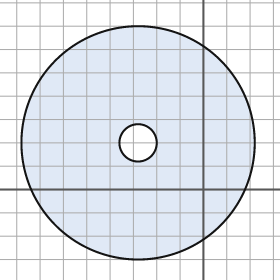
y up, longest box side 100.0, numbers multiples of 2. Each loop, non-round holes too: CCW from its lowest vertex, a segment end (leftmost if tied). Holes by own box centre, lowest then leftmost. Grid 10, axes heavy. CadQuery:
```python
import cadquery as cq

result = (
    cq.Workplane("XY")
    .moveTo(-28.0, 20.0)
    .circle(50.0)
    .moveTo(-28.0, 20.0)
    .circle(8.0)
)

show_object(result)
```